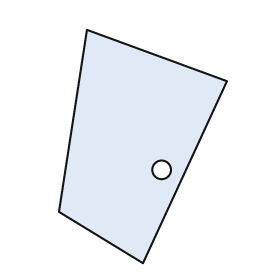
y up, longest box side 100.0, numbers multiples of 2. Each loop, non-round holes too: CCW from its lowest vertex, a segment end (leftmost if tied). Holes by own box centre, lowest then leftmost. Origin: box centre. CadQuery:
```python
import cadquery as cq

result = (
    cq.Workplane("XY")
    .moveTo(0.0, -50.0)
    .lineTo(36.0, 28.0)
    .lineTo(-24.0, 50.0)
    .lineTo(-36.0, -28.0)
    .close()
    .moveTo(8.0, -10.0)
    .circle(4.0)
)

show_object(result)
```